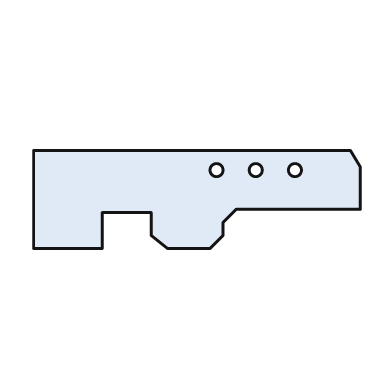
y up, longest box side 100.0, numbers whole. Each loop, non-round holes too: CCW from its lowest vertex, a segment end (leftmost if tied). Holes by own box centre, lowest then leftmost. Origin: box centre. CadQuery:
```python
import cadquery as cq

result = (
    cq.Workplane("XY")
    .moveTo(-50.0, -15.0)
    .lineTo(-29.0, -15.0)
    .lineTo(-29.0, -4.0)
    .lineTo(-14.0, -4.0)
    .lineTo(-14.0, -11.0)
    .lineTo(-9.0, -15.0)
    .lineTo(4.0, -15.0)
    .lineTo(8.0, -11.0)
    .lineTo(8.0, -7.0)
    .lineTo(12.0, -3.0)
    .lineTo(50.0, -3.0)
    .lineTo(50.0, 10.0)
    .lineTo(47.0, 15.0)
    .lineTo(-50.0, 15.0)
    .close()
    .moveTo(6.0, 9.0)
    .circle(2.0)
    .moveTo(18.0, 9.0)
    .circle(2.0)
    .moveTo(30.0, 9.0)
    .circle(2.0)
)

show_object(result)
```